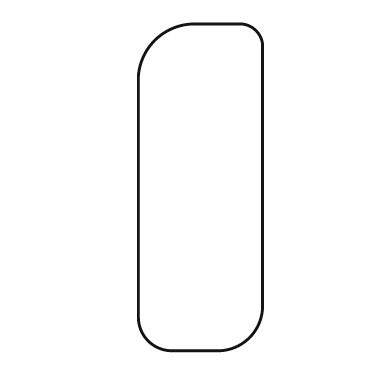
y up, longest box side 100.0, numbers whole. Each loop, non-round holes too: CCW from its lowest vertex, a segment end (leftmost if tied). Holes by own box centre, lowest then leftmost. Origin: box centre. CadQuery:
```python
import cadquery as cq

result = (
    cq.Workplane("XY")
    .moveTo(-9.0, -50.0)
    .lineTo(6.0, -50.0)
    .threePointArc((15.0, -46.0), (19.0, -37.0))
    .lineTo(19.0, 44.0)
    .threePointArc((17.0, 48.0), (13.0, 50.0))
    .lineTo(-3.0, 50.0)
    .threePointArc((-14.0, 45.0), (-19.0, 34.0))
    .lineTo(-19.0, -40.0)
    .threePointArc((-16.0, -47.0), (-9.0, -50.0))
    .close()
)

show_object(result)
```